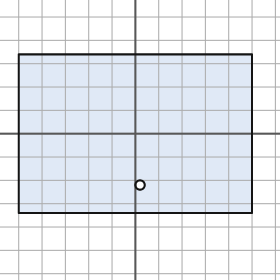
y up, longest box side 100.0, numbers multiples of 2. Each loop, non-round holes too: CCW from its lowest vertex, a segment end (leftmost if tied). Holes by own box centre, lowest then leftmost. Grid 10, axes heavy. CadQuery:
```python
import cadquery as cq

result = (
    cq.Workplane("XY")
    .moveTo(-50.0, -34.0)
    .lineTo(50.0, -34.0)
    .lineTo(50.0, 34.0)
    .lineTo(-50.0, 34.0)
    .close()
    .moveTo(2.0, -22.0)
    .circle(2.0)
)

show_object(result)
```